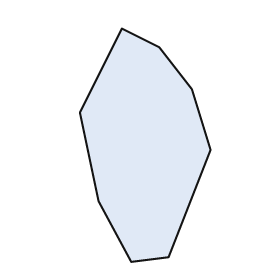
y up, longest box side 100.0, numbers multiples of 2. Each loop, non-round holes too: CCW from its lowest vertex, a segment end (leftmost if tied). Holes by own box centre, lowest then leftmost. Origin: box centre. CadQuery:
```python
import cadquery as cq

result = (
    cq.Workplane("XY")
    .moveTo(-6.0, -50.0)
    .lineTo(10.0, -48.0)
    .lineTo(28.0, -2.0)
    .lineTo(20.0, 24.0)
    .lineTo(6.0, 42.0)
    .lineTo(-10.0, 50.0)
    .lineTo(-28.0, 14.0)
    .lineTo(-20.0, -24.0)
    .close()
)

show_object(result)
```